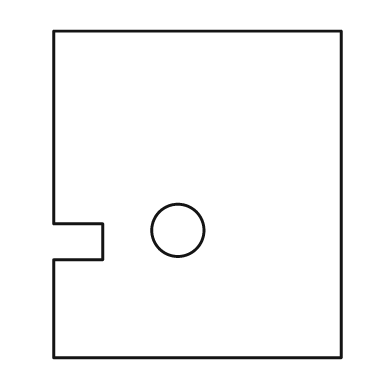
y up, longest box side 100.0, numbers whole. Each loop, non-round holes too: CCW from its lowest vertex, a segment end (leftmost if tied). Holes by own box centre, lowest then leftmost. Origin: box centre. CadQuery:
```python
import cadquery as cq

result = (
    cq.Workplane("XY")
    .moveTo(-44.0, -50.0)
    .lineTo(44.0, -50.0)
    .lineTo(44.0, 50.0)
    .lineTo(-44.0, 50.0)
    .lineTo(-44.0, -9.0)
    .lineTo(-29.0, -9.0)
    .lineTo(-29.0, -20.0)
    .lineTo(-44.0, -20.0)
    .close()
    .moveTo(-6.0, -11.0)
    .circle(8.0)
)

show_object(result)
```